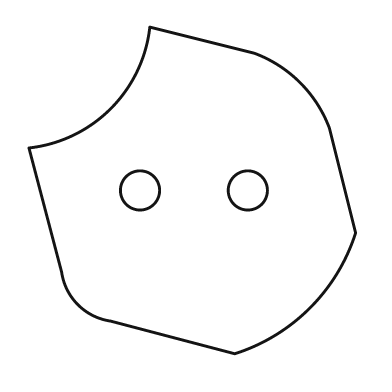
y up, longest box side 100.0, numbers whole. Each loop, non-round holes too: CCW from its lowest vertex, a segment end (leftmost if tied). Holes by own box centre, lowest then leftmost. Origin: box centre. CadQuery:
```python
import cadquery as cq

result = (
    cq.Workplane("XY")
    .moveTo(13.0, -50.0)
    .threePointArc((36.0, -36.0), (50.0, -13.0))
    .lineTo(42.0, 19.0)
    .threePointArc((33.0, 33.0), (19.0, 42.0))
    .lineTo(-13.0, 50.0)
    .threePointArc((-25.0, 25.0), (-50.0, 13.0))
    .lineTo(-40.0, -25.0)
    .threePointArc((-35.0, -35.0), (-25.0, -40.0))
    .close()
    .moveTo(-16.0, 0.0)
    .circle(6.0)
    .moveTo(17.0, 0.0)
    .circle(6.0)
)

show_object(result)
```